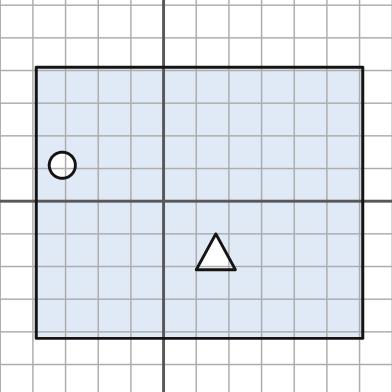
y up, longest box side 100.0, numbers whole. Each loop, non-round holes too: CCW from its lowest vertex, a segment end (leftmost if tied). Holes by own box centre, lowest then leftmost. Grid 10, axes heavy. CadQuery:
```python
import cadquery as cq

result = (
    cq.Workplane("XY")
    .moveTo(-39.0, -42.0)
    .lineTo(61.0, -42.0)
    .lineTo(61.0, 41.0)
    .lineTo(-39.0, 41.0)
    .close()
    .moveTo(10.0, -21.0)
    .lineTo(22.0, -21.0)
    .lineTo(16.0, -10.0)
    .close()
    .moveTo(-31.0, 11.0)
    .circle(4.0)
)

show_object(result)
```